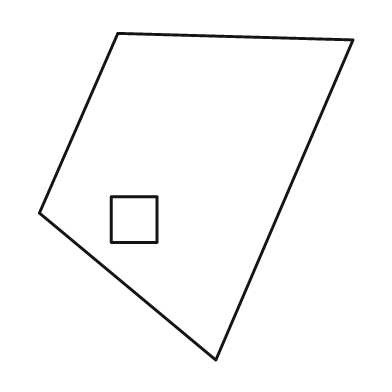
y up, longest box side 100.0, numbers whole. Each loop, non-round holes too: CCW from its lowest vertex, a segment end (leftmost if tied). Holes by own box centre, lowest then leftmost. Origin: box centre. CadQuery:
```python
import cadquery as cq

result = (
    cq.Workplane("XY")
    .moveTo(6.0, -50.0)
    .lineTo(48.0, 48.0)
    .lineTo(-24.0, 50.0)
    .lineTo(-48.0, -5.0)
    .close()
    .moveTo(-26.0, -14.0)
    .lineTo(-12.0, -14.0)
    .lineTo(-12.0, 0.0)
    .lineTo(-26.0, 0.0)
    .close()
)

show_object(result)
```